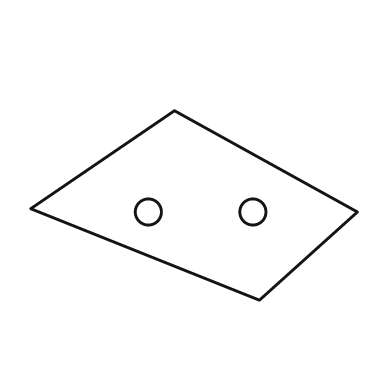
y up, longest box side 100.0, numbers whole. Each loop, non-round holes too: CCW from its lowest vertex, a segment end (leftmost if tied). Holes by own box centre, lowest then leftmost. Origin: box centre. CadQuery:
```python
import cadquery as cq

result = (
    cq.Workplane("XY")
    .moveTo(20.0, -29.0)
    .lineTo(50.0, -2.0)
    .lineTo(-6.0, 29.0)
    .lineTo(-50.0, -1.0)
    .close()
    .moveTo(-14.0, -2.0)
    .circle(4.0)
    .moveTo(18.0, -2.0)
    .circle(4.0)
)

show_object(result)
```